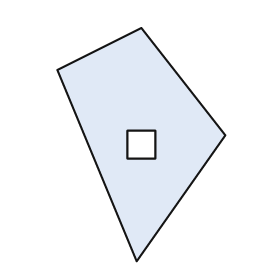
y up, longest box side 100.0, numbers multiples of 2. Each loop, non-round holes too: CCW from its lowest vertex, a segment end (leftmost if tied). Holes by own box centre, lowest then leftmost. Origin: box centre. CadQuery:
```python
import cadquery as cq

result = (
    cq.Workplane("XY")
    .moveTo(-2.0, -50.0)
    .lineTo(36.0, 4.0)
    .lineTo(0.0, 50.0)
    .lineTo(-36.0, 32.0)
    .close()
    .moveTo(-6.0, -6.0)
    .lineTo(6.0, -6.0)
    .lineTo(6.0, 6.0)
    .lineTo(-6.0, 6.0)
    .close()
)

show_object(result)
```